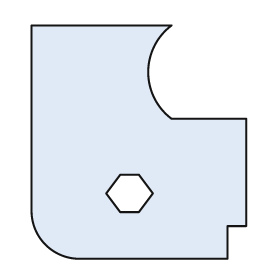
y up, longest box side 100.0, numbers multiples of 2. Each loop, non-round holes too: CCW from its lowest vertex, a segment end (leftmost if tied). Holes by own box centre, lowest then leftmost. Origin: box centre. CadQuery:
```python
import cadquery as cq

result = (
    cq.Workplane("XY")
    .moveTo(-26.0, -50.0)
    .lineTo(38.0, -50.0)
    .lineTo(38.0, -36.0)
    .lineTo(46.0, -36.0)
    .lineTo(46.0, 10.0)
    .lineTo(14.0, 10.0)
    .threePointArc((4.0, 30.0), (14.0, 50.0))
    .lineTo(-46.0, 50.0)
    .lineTo(-46.0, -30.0)
    .threePointArc((-40.0, -44.0), (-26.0, -50.0))
    .close()
    .moveTo(-8.0, -30.0)
    .lineTo(0.0, -30.0)
    .lineTo(6.0, -22.0)
    .lineTo(0.0, -14.0)
    .lineTo(-8.0, -14.0)
    .lineTo(-14.0, -22.0)
    .close()
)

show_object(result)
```